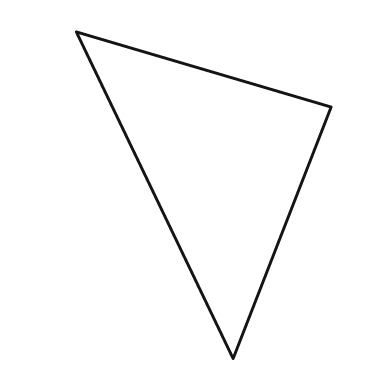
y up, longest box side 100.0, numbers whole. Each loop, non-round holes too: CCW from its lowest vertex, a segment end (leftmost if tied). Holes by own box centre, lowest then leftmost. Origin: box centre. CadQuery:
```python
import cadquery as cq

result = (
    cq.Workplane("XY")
    .moveTo(9.0, -50.0)
    .lineTo(39.0, 27.0)
    .lineTo(-39.0, 50.0)
    .close()
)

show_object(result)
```